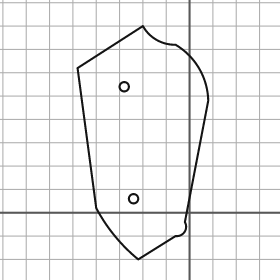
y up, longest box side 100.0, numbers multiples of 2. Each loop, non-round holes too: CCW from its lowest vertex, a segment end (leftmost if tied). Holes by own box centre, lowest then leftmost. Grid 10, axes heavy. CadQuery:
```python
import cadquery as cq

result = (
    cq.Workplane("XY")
    .moveTo(-22.0, -20.0)
    .lineTo(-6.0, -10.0)
    .threePointArc((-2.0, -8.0), (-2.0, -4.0))
    .lineTo(8.0, 48.0)
    .threePointArc((4.0, 62.0), (-6.0, 72.0))
    .threePointArc((-14.0, 74.0), (-20.0, 80.0))
    .lineTo(-48.0, 62.0)
    .lineTo(-40.0, 2.0)
    .threePointArc((-32.0, -10.0), (-22.0, -20.0))
    .close()
    .moveTo(-24.0, 6.0)
    .circle(2.0)
    .moveTo(-28.0, 54.0)
    .circle(2.0)
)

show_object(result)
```